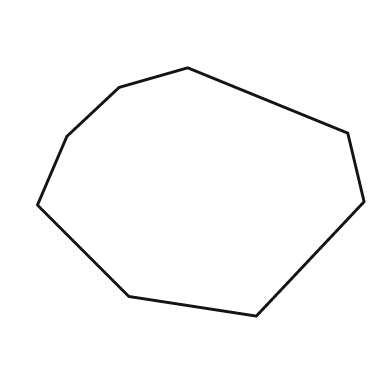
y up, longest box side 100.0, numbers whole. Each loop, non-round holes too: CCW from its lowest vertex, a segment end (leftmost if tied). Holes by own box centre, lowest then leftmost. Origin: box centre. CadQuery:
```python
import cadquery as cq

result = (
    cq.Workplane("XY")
    .moveTo(17.0, -38.0)
    .lineTo(50.0, -3.0)
    .lineTo(45.0, 18.0)
    .lineTo(-4.0, 38.0)
    .lineTo(-25.0, 32.0)
    .lineTo(-41.0, 17.0)
    .lineTo(-50.0, -4.0)
    .lineTo(-22.0, -32.0)
    .close()
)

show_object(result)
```